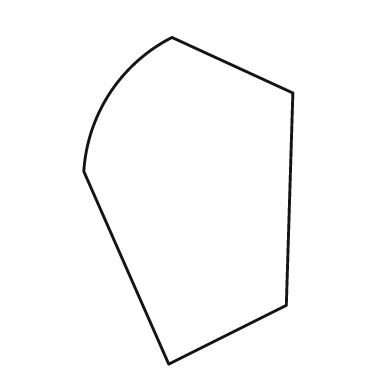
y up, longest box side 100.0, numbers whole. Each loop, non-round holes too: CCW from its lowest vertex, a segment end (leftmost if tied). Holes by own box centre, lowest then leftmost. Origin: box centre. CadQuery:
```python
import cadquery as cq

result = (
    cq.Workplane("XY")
    .moveTo(-6.0, -50.0)
    .lineTo(30.0, -32.0)
    .lineTo(32.0, 33.0)
    .lineTo(-5.0, 50.0)
    .threePointArc((-24.0, 33.0), (-32.0, 9.0))
    .close()
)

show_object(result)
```